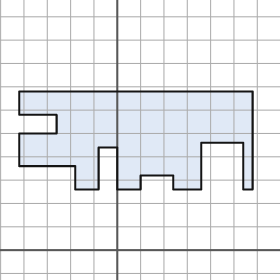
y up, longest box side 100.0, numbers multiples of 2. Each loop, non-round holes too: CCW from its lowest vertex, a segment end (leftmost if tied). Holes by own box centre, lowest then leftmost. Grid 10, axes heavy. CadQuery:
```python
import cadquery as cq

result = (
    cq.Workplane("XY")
    .moveTo(-18.0, 26.0)
    .lineTo(-8.0, 26.0)
    .lineTo(-8.0, 44.0)
    .lineTo(0.0, 44.0)
    .lineTo(0.0, 26.0)
    .lineTo(10.0, 26.0)
    .lineTo(10.0, 32.0)
    .lineTo(24.0, 32.0)
    .lineTo(24.0, 26.0)
    .lineTo(36.0, 26.0)
    .lineTo(36.0, 46.0)
    .lineTo(54.0, 46.0)
    .lineTo(54.0, 26.0)
    .lineTo(58.0, 26.0)
    .lineTo(58.0, 68.0)
    .lineTo(-42.0, 68.0)
    .lineTo(-42.0, 58.0)
    .lineTo(-26.0, 58.0)
    .lineTo(-26.0, 50.0)
    .lineTo(-42.0, 50.0)
    .lineTo(-42.0, 36.0)
    .lineTo(-18.0, 36.0)
    .close()
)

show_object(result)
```